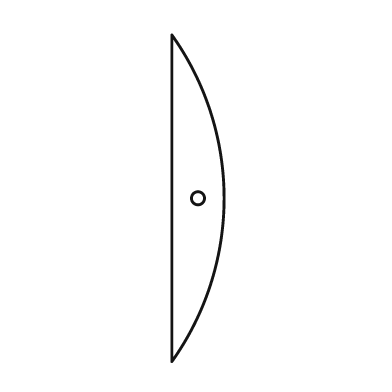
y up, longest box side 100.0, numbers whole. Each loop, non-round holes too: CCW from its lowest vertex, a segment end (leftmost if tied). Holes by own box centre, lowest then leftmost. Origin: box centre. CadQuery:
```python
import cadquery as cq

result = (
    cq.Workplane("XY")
    .moveTo(-8.0, -50.0)
    .threePointArc((8.0, 0.0), (-8.0, 50.0))
    .close()
    .moveTo(0.0, 0.0)
    .circle(2.0)
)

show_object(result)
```